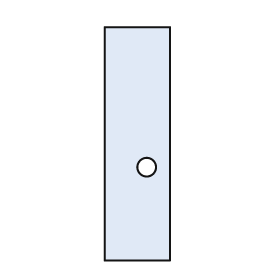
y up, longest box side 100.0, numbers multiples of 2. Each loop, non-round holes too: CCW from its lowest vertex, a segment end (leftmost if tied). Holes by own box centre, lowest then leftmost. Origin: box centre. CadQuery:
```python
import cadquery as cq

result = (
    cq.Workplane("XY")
    .moveTo(-14.0, -50.0)
    .lineTo(14.0, -50.0)
    .lineTo(14.0, 50.0)
    .lineTo(-14.0, 50.0)
    .close()
    .moveTo(4.0, -10.0)
    .circle(4.0)
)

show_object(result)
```